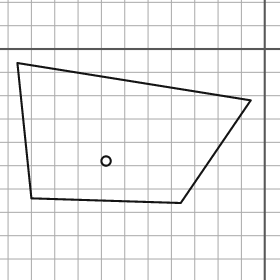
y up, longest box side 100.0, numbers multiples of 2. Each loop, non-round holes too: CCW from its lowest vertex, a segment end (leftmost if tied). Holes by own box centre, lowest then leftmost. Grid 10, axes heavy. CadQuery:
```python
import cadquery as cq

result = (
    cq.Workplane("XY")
    .moveTo(-36.0, -66.0)
    .lineTo(-6.0, -22.0)
    .lineTo(-106.0, -6.0)
    .lineTo(-100.0, -64.0)
    .close()
    .moveTo(-68.0, -48.0)
    .circle(2.0)
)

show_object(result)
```